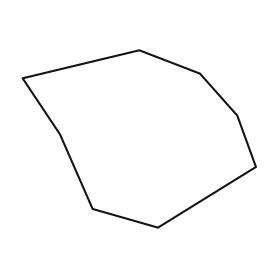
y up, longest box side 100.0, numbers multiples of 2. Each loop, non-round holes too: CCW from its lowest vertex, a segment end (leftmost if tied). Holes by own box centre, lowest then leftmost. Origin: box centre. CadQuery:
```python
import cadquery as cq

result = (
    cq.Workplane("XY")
    .moveTo(8.0, -38.0)
    .lineTo(50.0, -12.0)
    .lineTo(42.0, 10.0)
    .lineTo(26.0, 28.0)
    .lineTo(0.0, 38.0)
    .lineTo(-50.0, 26.0)
    .lineTo(-34.0, 2.0)
    .lineTo(-20.0, -30.0)
    .close()
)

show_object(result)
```